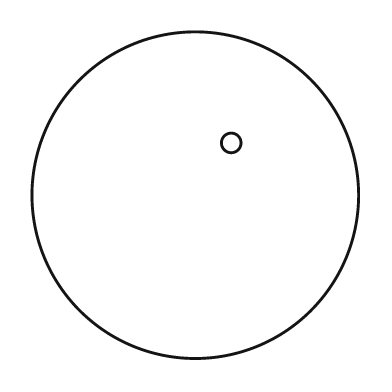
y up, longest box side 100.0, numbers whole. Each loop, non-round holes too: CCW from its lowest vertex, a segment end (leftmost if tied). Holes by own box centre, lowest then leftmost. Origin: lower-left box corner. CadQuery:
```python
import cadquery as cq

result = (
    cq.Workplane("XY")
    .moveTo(50.0, 50.0)
    .circle(50.0)
    .moveTo(61.0, 66.0)
    .circle(3.0)
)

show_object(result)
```